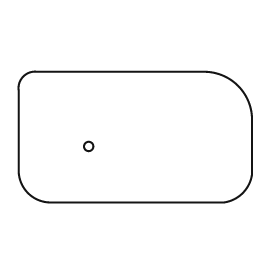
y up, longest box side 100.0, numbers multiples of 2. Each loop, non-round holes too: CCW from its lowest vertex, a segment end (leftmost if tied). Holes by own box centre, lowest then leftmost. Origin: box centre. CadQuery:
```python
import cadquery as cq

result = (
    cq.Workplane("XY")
    .moveTo(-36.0, -28.0)
    .lineTo(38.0, -28.0)
    .threePointArc((46.0, -24.0), (50.0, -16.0))
    .lineTo(50.0, 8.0)
    .threePointArc((44.0, 22.0), (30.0, 28.0))
    .lineTo(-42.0, 28.0)
    .threePointArc((-48.0, 26.0), (-50.0, 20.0))
    .lineTo(-50.0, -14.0)
    .threePointArc((-46.0, -24.0), (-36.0, -28.0))
    .close()
    .moveTo(-20.0, -4.0)
    .circle(2.0)
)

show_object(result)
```